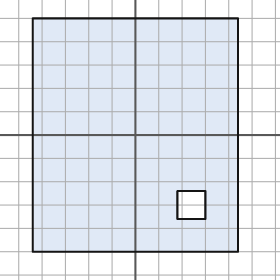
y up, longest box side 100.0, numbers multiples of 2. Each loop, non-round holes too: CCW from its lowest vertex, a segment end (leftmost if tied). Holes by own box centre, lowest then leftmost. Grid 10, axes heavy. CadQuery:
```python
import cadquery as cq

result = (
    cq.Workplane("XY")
    .moveTo(-44.0, -50.0)
    .lineTo(44.0, -50.0)
    .lineTo(44.0, 50.0)
    .lineTo(-44.0, 50.0)
    .close()
    .moveTo(18.0, -36.0)
    .lineTo(30.0, -36.0)
    .lineTo(30.0, -24.0)
    .lineTo(18.0, -24.0)
    .close()
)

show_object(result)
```